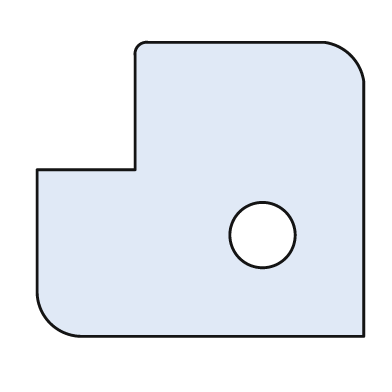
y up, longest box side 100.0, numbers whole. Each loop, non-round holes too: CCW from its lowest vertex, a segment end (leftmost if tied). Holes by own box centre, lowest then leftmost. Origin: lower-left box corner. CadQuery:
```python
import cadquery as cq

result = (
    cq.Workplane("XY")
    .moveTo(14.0, 0.0)
    .lineTo(100.0, 0.0)
    .lineTo(100.0, 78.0)
    .threePointArc((96.0, 86.0), (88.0, 90.0))
    .lineTo(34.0, 90.0)
    .threePointArc((31.0, 89.0), (30.0, 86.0))
    .lineTo(30.0, 51.0)
    .lineTo(0.0, 51.0)
    .lineTo(0.0, 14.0)
    .threePointArc((4.0, 4.0), (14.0, 0.0))
    .close()
    .moveTo(69.0, 31.0)
    .circle(10.0)
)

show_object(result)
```